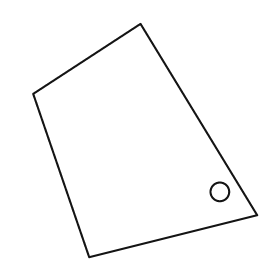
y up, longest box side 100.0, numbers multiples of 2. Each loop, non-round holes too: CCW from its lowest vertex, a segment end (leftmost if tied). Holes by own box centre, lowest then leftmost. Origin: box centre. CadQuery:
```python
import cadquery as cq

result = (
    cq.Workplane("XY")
    .moveTo(-24.0, -50.0)
    .lineTo(48.0, -32.0)
    .lineTo(-2.0, 50.0)
    .lineTo(-48.0, 20.0)
    .close()
    .moveTo(32.0, -22.0)
    .circle(4.0)
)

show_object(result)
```